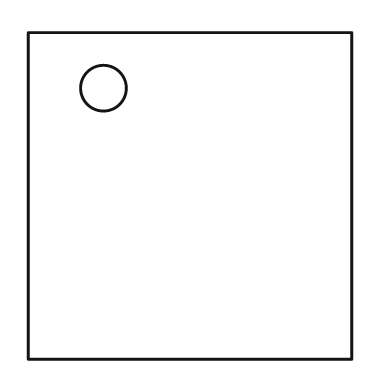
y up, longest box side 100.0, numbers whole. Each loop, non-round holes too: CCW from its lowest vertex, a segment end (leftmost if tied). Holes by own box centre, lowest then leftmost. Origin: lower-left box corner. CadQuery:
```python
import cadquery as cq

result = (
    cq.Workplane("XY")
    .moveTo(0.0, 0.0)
    .lineTo(99.0, 0.0)
    .lineTo(99.0, 100.0)
    .lineTo(0.0, 100.0)
    .close()
    .moveTo(23.0, 83.0)
    .circle(7.0)
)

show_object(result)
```